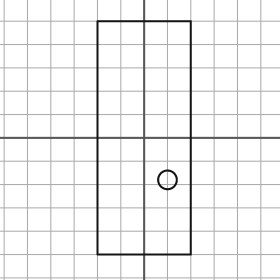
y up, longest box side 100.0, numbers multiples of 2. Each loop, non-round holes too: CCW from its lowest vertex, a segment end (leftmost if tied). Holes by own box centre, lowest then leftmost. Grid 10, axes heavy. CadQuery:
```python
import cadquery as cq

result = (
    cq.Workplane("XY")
    .moveTo(-20.0, -50.0)
    .lineTo(20.0, -50.0)
    .lineTo(20.0, 50.0)
    .lineTo(-20.0, 50.0)
    .close()
    .moveTo(10.0, -18.0)
    .circle(4.0)
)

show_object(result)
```